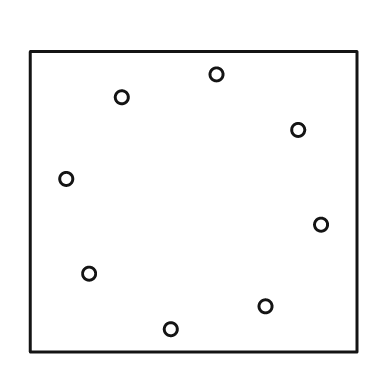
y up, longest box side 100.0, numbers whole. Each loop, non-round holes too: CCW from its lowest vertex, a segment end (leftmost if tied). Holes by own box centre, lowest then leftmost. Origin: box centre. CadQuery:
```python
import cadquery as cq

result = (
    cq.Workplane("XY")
    .moveTo(-50.0, -46.0)
    .lineTo(50.0, -46.0)
    .lineTo(50.0, 46.0)
    .lineTo(-50.0, 46.0)
    .close()
    .moveTo(-7.0, -39.0)
    .circle(2.0)
    .moveTo(22.0, -32.0)
    .circle(2.0)
    .moveTo(-32.0, -22.0)
    .circle(2.0)
    .moveTo(39.0, -7.0)
    .circle(2.0)
    .moveTo(-39.0, 7.0)
    .circle(2.0)
    .moveTo(32.0, 22.0)
    .circle(2.0)
    .moveTo(-22.0, 32.0)
    .circle(2.0)
    .moveTo(7.0, 39.0)
    .circle(2.0)
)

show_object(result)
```